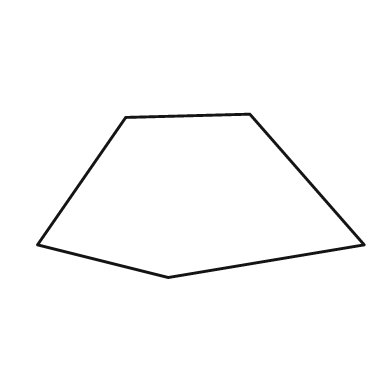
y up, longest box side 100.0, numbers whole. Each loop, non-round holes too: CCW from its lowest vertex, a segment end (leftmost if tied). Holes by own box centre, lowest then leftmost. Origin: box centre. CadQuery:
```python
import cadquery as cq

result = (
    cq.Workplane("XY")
    .moveTo(-10.0, -25.0)
    .lineTo(50.0, -15.0)
    .lineTo(15.0, 25.0)
    .lineTo(-23.0, 24.0)
    .lineTo(-50.0, -15.0)
    .close()
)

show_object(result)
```